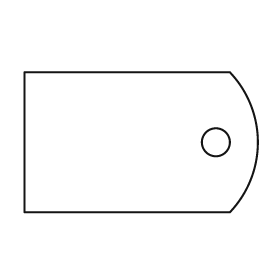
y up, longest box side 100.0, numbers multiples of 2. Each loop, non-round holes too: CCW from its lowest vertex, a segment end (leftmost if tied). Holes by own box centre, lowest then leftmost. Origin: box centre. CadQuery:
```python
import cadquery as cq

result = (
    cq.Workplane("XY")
    .moveTo(-50.0, -30.0)
    .lineTo(38.0, -30.0)
    .threePointArc((50.0, 0.0), (38.0, 30.0))
    .lineTo(-50.0, 30.0)
    .close()
    .moveTo(32.0, 0.0)
    .circle(6.0)
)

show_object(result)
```